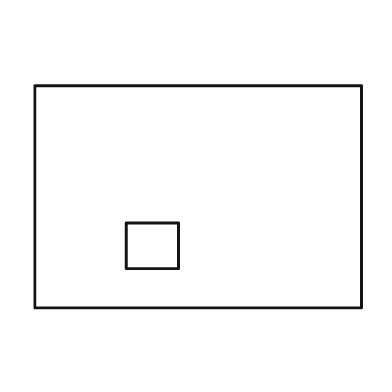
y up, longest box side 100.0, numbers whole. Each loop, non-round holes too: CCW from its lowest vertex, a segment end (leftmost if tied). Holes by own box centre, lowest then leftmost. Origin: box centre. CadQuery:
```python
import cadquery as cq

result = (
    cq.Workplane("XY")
    .moveTo(-50.0, -34.0)
    .lineTo(50.0, -34.0)
    .lineTo(50.0, 34.0)
    .lineTo(-50.0, 34.0)
    .close()
    .moveTo(-22.0, -22.0)
    .lineTo(-6.0, -22.0)
    .lineTo(-6.0, -8.0)
    .lineTo(-22.0, -8.0)
    .close()
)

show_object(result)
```